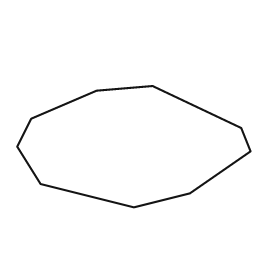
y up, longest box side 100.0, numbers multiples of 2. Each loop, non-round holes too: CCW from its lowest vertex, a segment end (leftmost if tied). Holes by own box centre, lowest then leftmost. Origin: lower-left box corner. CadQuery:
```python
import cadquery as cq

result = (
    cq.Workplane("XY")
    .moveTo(50.0, 0.0)
    .lineTo(74.0, 6.0)
    .lineTo(100.0, 24.0)
    .lineTo(96.0, 34.0)
    .lineTo(58.0, 52.0)
    .lineTo(34.0, 50.0)
    .lineTo(6.0, 38.0)
    .lineTo(0.0, 26.0)
    .lineTo(10.0, 10.0)
    .close()
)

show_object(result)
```